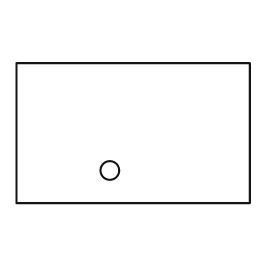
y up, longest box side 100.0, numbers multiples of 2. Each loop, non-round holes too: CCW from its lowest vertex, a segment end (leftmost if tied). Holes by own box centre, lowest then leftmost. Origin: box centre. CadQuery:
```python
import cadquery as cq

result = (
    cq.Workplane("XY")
    .moveTo(-50.0, -30.0)
    .lineTo(50.0, -30.0)
    .lineTo(50.0, 30.0)
    .lineTo(-50.0, 30.0)
    .close()
    .moveTo(-10.0, -16.0)
    .circle(4.0)
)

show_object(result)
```